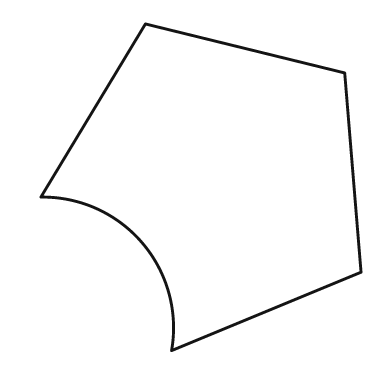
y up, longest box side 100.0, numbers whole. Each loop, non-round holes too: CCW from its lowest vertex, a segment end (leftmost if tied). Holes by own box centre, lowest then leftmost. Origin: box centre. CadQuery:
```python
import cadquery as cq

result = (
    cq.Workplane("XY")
    .moveTo(-9.0, -50.0)
    .lineTo(49.0, -26.0)
    .lineTo(44.0, 35.0)
    .lineTo(-17.0, 50.0)
    .lineTo(-49.0, -3.0)
    .threePointArc((-18.0, -17.0), (-9.0, -50.0))
    .close()
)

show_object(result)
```